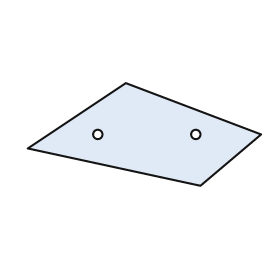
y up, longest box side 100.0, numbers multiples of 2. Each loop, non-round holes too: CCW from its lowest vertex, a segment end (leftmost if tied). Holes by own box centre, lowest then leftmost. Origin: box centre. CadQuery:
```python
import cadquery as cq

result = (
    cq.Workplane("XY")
    .moveTo(24.0, -22.0)
    .lineTo(50.0, 0.0)
    .lineTo(-8.0, 22.0)
    .lineTo(-50.0, -6.0)
    .close()
    .moveTo(-20.0, 0.0)
    .circle(2.0)
    .moveTo(22.0, 0.0)
    .circle(2.0)
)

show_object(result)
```